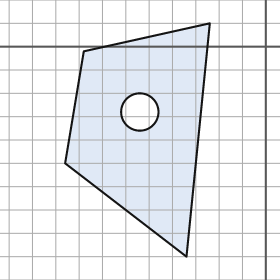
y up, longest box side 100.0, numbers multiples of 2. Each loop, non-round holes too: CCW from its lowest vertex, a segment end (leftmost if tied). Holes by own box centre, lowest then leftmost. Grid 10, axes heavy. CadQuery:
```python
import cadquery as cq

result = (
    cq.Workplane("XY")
    .moveTo(-34.0, -90.0)
    .lineTo(-24.0, 10.0)
    .lineTo(-78.0, -2.0)
    .lineTo(-86.0, -50.0)
    .close()
    .moveTo(-54.0, -28.0)
    .circle(8.0)
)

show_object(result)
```